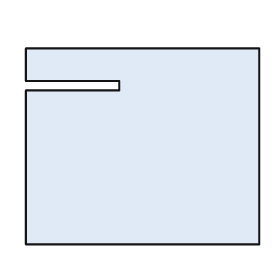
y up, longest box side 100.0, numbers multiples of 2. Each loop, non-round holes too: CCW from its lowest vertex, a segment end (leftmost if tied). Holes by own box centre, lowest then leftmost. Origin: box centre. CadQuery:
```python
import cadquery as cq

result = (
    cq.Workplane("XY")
    .moveTo(-50.0, -42.0)
    .lineTo(50.0, -42.0)
    .lineTo(50.0, 42.0)
    .lineTo(-50.0, 42.0)
    .lineTo(-50.0, 28.0)
    .lineTo(-10.0, 28.0)
    .lineTo(-10.0, 24.0)
    .lineTo(-50.0, 24.0)
    .close()
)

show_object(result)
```